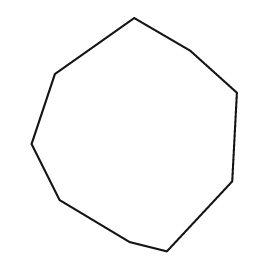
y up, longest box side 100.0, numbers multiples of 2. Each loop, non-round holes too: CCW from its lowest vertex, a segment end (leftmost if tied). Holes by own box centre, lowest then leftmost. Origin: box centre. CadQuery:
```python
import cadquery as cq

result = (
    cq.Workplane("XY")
    .moveTo(14.0, -50.0)
    .lineTo(42.0, -20.0)
    .lineTo(44.0, 18.0)
    .lineTo(24.0, 36.0)
    .lineTo(0.0, 50.0)
    .lineTo(-34.0, 26.0)
    .lineTo(-44.0, -4.0)
    .lineTo(-32.0, -28.0)
    .lineTo(-2.0, -46.0)
    .close()
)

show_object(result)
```